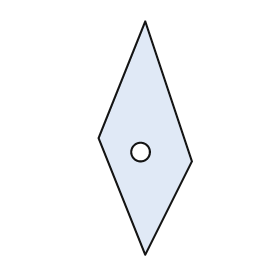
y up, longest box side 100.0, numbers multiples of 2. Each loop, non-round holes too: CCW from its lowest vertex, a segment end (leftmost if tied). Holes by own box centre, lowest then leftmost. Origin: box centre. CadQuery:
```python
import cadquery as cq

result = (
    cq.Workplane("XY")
    .moveTo(0.0, -50.0)
    .lineTo(20.0, -10.0)
    .lineTo(0.0, 50.0)
    .lineTo(-20.0, 0.0)
    .close()
    .moveTo(-2.0, -6.0)
    .circle(4.0)
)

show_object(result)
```